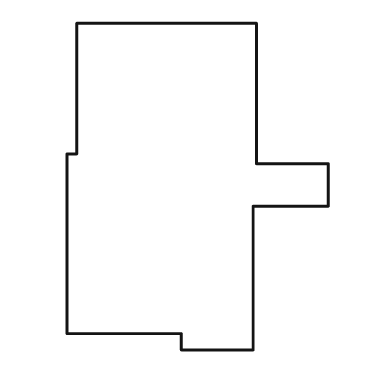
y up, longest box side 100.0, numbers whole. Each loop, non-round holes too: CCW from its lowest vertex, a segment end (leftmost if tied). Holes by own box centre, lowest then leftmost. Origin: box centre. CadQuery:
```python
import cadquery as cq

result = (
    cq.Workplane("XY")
    .moveTo(-5.0, -50.0)
    .lineTo(17.0, -50.0)
    .lineTo(17.0, -6.0)
    .lineTo(40.0, -6.0)
    .lineTo(40.0, 7.0)
    .lineTo(18.0, 7.0)
    .lineTo(18.0, 50.0)
    .lineTo(-37.0, 50.0)
    .lineTo(-37.0, 10.0)
    .lineTo(-40.0, 10.0)
    .lineTo(-40.0, -45.0)
    .lineTo(-5.0, -45.0)
    .close()
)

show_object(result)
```